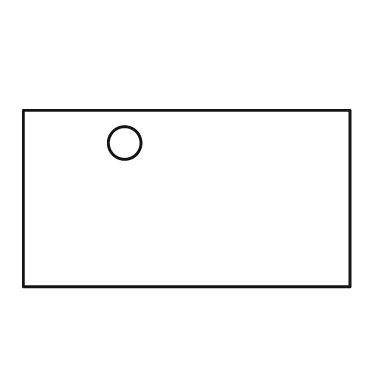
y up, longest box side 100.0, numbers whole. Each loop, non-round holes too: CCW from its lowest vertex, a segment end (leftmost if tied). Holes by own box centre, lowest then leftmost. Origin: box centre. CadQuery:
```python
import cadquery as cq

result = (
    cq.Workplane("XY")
    .moveTo(-50.0, -27.0)
    .lineTo(50.0, -27.0)
    .lineTo(50.0, 27.0)
    .lineTo(-50.0, 27.0)
    .close()
    .moveTo(-19.0, 17.0)
    .circle(5.0)
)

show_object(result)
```